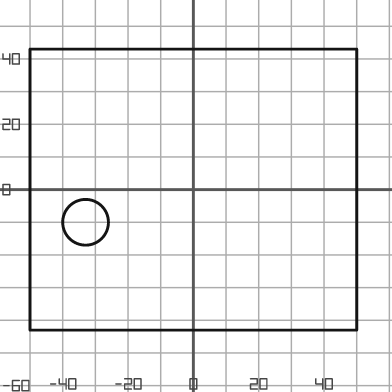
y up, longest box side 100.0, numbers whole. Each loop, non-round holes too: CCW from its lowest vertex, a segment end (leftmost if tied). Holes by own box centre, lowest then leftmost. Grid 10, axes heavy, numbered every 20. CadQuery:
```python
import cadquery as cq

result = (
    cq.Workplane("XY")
    .moveTo(-50.0, -43.0)
    .lineTo(50.0, -43.0)
    .lineTo(50.0, 43.0)
    .lineTo(-50.0, 43.0)
    .close()
    .moveTo(-33.0, -10.0)
    .circle(7.0)
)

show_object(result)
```